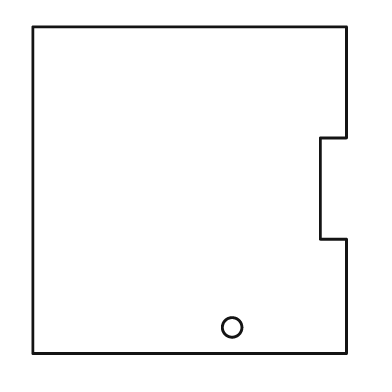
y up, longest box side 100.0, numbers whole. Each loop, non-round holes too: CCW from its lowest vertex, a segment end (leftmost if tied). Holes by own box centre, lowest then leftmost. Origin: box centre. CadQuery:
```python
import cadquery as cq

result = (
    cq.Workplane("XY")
    .moveTo(-48.0, -50.0)
    .lineTo(48.0, -50.0)
    .lineTo(48.0, -15.0)
    .lineTo(40.0, -15.0)
    .lineTo(40.0, 16.0)
    .lineTo(48.0, 16.0)
    .lineTo(48.0, 50.0)
    .lineTo(-48.0, 50.0)
    .close()
    .moveTo(13.0, -42.0)
    .circle(3.0)
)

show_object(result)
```